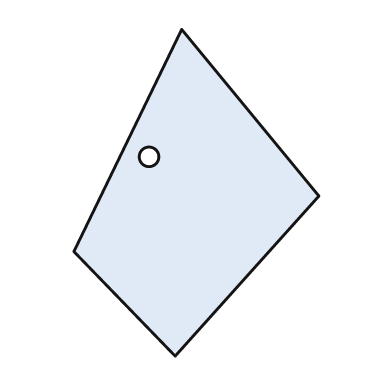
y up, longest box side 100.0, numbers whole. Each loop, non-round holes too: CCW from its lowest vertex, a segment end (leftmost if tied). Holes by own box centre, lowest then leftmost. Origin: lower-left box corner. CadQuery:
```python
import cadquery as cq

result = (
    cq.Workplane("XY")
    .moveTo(31.0, 0.0)
    .lineTo(75.0, 49.0)
    .lineTo(33.0, 100.0)
    .lineTo(0.0, 32.0)
    .close()
    .moveTo(23.0, 61.0)
    .circle(3.0)
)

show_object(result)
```